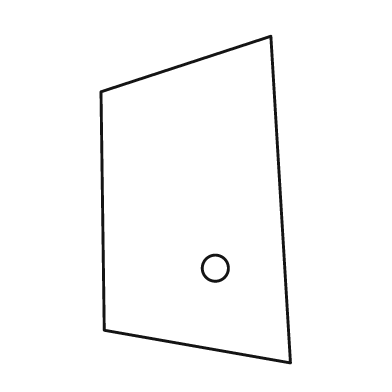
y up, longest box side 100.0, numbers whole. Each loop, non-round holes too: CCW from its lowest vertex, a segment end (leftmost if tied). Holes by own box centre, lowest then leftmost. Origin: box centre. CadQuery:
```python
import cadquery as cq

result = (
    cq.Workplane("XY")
    .moveTo(29.0, -50.0)
    .lineTo(23.0, 50.0)
    .lineTo(-29.0, 33.0)
    .lineTo(-28.0, -40.0)
    .close()
    .moveTo(6.0, -21.0)
    .circle(4.0)
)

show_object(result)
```